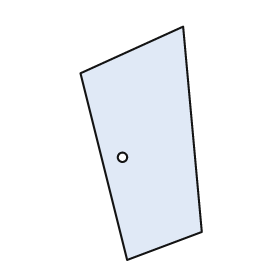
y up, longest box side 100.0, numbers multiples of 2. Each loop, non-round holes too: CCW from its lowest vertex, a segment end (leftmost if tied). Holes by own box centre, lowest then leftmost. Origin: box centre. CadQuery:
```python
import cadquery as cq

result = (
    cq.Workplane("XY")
    .moveTo(-6.0, -50.0)
    .lineTo(26.0, -38.0)
    .lineTo(18.0, 50.0)
    .lineTo(-26.0, 30.0)
    .close()
    .moveTo(-8.0, -6.0)
    .circle(2.0)
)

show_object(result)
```